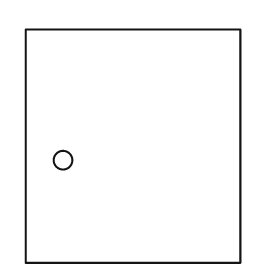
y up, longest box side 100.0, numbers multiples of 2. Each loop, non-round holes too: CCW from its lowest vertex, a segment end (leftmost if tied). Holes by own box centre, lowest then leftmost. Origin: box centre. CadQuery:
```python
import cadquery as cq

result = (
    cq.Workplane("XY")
    .moveTo(-46.0, -50.0)
    .lineTo(46.0, -50.0)
    .lineTo(46.0, 50.0)
    .lineTo(-46.0, 50.0)
    .close()
    .moveTo(-30.0, -6.0)
    .circle(4.0)
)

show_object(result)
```